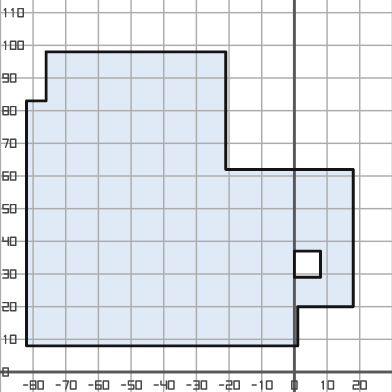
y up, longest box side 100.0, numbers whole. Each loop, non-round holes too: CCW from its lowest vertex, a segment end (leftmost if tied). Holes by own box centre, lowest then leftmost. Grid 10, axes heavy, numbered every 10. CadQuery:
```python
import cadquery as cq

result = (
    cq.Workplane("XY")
    .moveTo(-82.0, 8.0)
    .lineTo(1.0, 8.0)
    .lineTo(1.0, 20.0)
    .lineTo(18.0, 20.0)
    .lineTo(18.0, 62.0)
    .lineTo(-21.0, 62.0)
    .lineTo(-21.0, 98.0)
    .lineTo(-76.0, 98.0)
    .lineTo(-76.0, 83.0)
    .lineTo(-82.0, 83.0)
    .close()
    .moveTo(0.0, 29.0)
    .lineTo(8.0, 29.0)
    .lineTo(8.0, 37.0)
    .lineTo(0.0, 37.0)
    .close()
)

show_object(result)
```